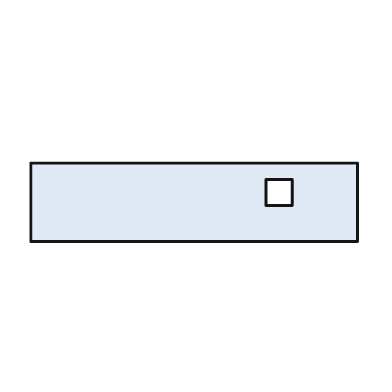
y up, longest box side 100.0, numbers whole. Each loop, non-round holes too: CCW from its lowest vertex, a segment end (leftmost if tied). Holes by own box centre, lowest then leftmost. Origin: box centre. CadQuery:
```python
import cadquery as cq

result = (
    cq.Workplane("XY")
    .moveTo(-50.0, -12.0)
    .lineTo(50.0, -12.0)
    .lineTo(50.0, 12.0)
    .lineTo(-50.0, 12.0)
    .close()
    .moveTo(22.0, -1.0)
    .lineTo(30.0, -1.0)
    .lineTo(30.0, 7.0)
    .lineTo(22.0, 7.0)
    .close()
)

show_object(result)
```